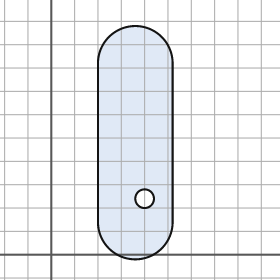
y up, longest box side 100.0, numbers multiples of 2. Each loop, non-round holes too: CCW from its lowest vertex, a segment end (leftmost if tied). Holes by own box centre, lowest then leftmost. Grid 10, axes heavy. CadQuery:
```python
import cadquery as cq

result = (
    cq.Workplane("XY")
    .moveTo(20.0, 14.0)
    .threePointArc((36.0, -2.0), (52.0, 14.0))
    .lineTo(52.0, 82.0)
    .threePointArc((36.0, 98.0), (20.0, 82.0))
    .close()
    .moveTo(40.0, 24.0)
    .circle(4.0)
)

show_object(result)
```